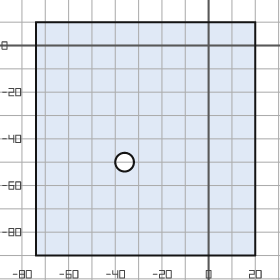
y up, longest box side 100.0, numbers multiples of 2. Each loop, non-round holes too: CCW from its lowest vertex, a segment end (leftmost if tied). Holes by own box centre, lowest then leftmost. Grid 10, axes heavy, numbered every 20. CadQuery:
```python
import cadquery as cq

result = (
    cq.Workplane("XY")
    .moveTo(-74.0, -90.0)
    .lineTo(20.0, -90.0)
    .lineTo(20.0, 10.0)
    .lineTo(-74.0, 10.0)
    .close()
    .moveTo(-36.0, -50.0)
    .circle(4.0)
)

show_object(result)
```